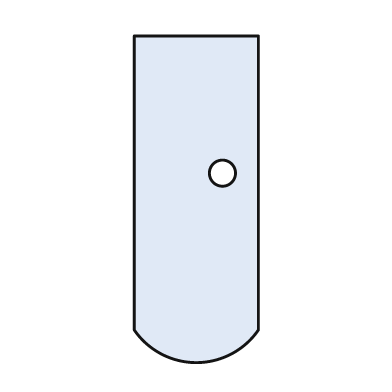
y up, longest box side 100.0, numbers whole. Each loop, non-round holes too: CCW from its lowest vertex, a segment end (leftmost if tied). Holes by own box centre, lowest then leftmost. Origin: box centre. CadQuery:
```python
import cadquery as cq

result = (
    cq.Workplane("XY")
    .moveTo(-19.0, -40.0)
    .threePointArc((0.0, -50.0), (19.0, -40.0))
    .lineTo(19.0, 50.0)
    .lineTo(-19.0, 50.0)
    .close()
    .moveTo(8.0, 8.0)
    .circle(4.0)
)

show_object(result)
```